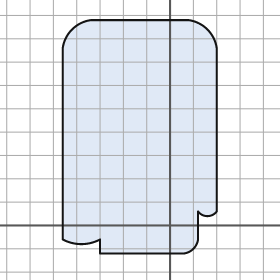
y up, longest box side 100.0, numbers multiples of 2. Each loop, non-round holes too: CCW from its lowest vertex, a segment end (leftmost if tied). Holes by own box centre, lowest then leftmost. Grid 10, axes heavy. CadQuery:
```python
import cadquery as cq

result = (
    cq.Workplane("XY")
    .moveTo(-30.0, -12.0)
    .lineTo(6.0, -12.0)
    .threePointArc((10.0, -10.0), (12.0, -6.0))
    .lineTo(12.0, 6.0)
    .threePointArc((16.0, 4.0), (20.0, 6.0))
    .lineTo(20.0, 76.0)
    .threePointArc((16.0, 84.0), (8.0, 88.0))
    .lineTo(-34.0, 88.0)
    .threePointArc((-42.0, 84.0), (-46.0, 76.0))
    .lineTo(-46.0, -6.0)
    .threePointArc((-38.0, -8.0), (-30.0, -6.0))
    .close()
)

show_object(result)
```